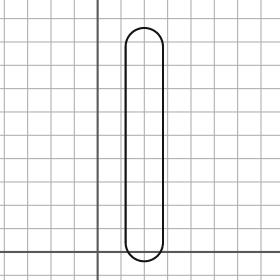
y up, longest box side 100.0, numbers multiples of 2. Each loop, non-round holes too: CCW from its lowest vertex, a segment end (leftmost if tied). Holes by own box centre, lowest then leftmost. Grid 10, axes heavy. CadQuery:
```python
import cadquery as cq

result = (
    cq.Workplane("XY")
    .moveTo(12.0, 4.0)
    .threePointArc((20.0, -4.0), (28.0, 4.0))
    .lineTo(28.0, 88.0)
    .threePointArc((20.0, 96.0), (12.0, 88.0))
    .close()
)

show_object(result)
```